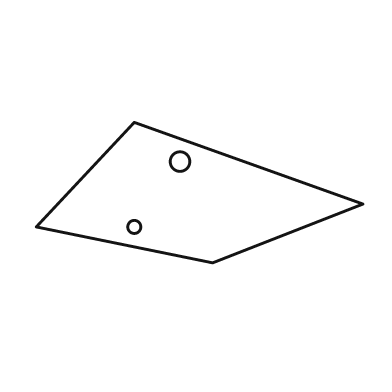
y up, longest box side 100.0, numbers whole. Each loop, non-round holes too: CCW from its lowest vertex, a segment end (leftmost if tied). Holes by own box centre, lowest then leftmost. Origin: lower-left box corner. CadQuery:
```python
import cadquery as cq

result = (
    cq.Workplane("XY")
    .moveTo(54.0, 0.0)
    .lineTo(100.0, 18.0)
    .lineTo(30.0, 43.0)
    .lineTo(0.0, 11.0)
    .close()
    .moveTo(30.0, 11.0)
    .circle(2.0)
    .moveTo(44.0, 31.0)
    .circle(3.0)
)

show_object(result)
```